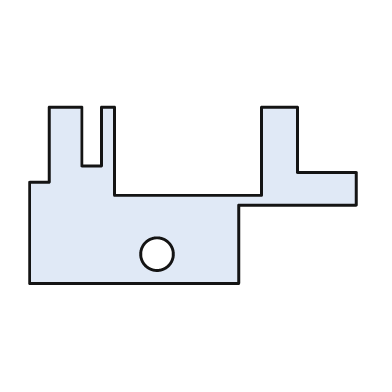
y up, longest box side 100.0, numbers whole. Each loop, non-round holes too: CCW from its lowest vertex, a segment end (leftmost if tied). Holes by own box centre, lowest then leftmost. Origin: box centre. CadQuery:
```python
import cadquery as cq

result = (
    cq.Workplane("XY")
    .moveTo(-50.0, -27.0)
    .lineTo(14.0, -27.0)
    .lineTo(14.0, -3.0)
    .lineTo(50.0, -3.0)
    .lineTo(50.0, 7.0)
    .lineTo(32.0, 7.0)
    .lineTo(32.0, 27.0)
    .lineTo(21.0, 27.0)
    .lineTo(21.0, 0.0)
    .lineTo(-24.0, 0.0)
    .lineTo(-24.0, 27.0)
    .lineTo(-28.0, 27.0)
    .lineTo(-28.0, 9.0)
    .lineTo(-34.0, 9.0)
    .lineTo(-34.0, 27.0)
    .lineTo(-44.0, 27.0)
    .lineTo(-44.0, 4.0)
    .lineTo(-50.0, 4.0)
    .close()
    .moveTo(-11.0, -18.0)
    .circle(5.0)
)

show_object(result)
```